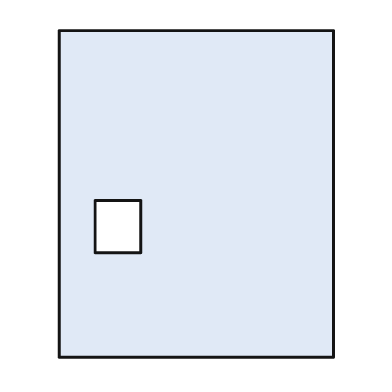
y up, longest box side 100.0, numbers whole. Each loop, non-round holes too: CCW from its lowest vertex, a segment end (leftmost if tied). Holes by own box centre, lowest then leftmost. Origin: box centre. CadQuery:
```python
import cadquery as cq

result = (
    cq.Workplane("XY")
    .moveTo(-42.0, -50.0)
    .lineTo(42.0, -50.0)
    .lineTo(42.0, 50.0)
    .lineTo(-42.0, 50.0)
    .close()
    .moveTo(-31.0, -18.0)
    .lineTo(-17.0, -18.0)
    .lineTo(-17.0, -2.0)
    .lineTo(-31.0, -2.0)
    .close()
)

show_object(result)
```